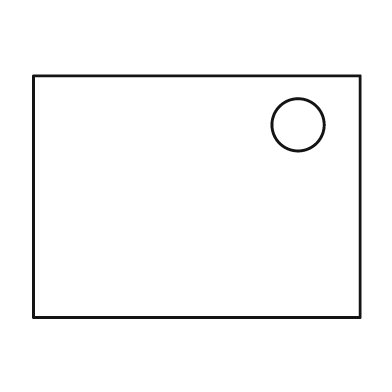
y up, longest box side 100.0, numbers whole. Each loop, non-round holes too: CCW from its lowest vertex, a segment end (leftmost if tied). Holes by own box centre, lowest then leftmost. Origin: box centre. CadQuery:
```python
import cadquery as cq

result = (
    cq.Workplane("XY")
    .moveTo(-50.0, -37.0)
    .lineTo(50.0, -37.0)
    .lineTo(50.0, 37.0)
    .lineTo(-50.0, 37.0)
    .close()
    .moveTo(31.0, 22.0)
    .circle(8.0)
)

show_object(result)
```